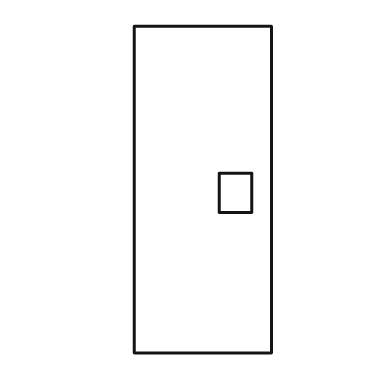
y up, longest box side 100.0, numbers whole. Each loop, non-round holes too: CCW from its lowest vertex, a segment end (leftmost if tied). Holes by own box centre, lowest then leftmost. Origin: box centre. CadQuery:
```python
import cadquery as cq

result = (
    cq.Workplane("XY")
    .moveTo(-21.0, -50.0)
    .lineTo(21.0, -50.0)
    .lineTo(21.0, 50.0)
    .lineTo(-21.0, 50.0)
    .close()
    .moveTo(5.0, -7.0)
    .lineTo(15.0, -7.0)
    .lineTo(15.0, 5.0)
    .lineTo(5.0, 5.0)
    .close()
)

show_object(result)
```